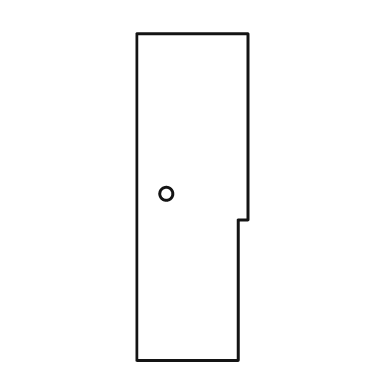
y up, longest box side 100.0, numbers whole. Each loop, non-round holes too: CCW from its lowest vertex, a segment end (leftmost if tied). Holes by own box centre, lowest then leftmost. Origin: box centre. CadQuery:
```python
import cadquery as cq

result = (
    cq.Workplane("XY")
    .moveTo(-17.0, -50.0)
    .lineTo(14.0, -50.0)
    .lineTo(14.0, -7.0)
    .lineTo(17.0, -7.0)
    .lineTo(17.0, 50.0)
    .lineTo(-17.0, 50.0)
    .close()
    .moveTo(-8.0, 1.0)
    .circle(2.0)
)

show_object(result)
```